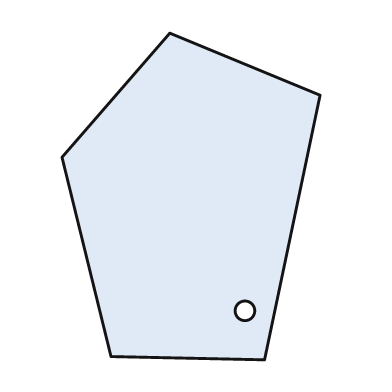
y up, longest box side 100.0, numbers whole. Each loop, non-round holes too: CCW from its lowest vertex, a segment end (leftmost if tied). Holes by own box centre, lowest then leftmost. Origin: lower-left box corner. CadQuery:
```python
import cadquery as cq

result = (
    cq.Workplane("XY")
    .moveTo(62.0, 0.0)
    .lineTo(79.0, 81.0)
    .lineTo(33.0, 100.0)
    .lineTo(0.0, 62.0)
    .lineTo(15.0, 1.0)
    .close()
    .moveTo(56.0, 15.0)
    .circle(3.0)
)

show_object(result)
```